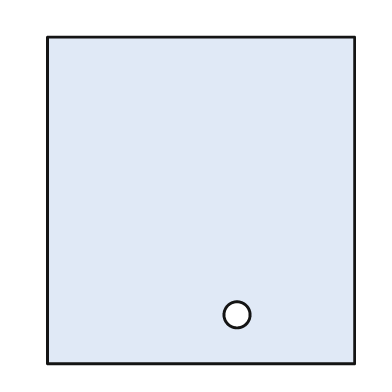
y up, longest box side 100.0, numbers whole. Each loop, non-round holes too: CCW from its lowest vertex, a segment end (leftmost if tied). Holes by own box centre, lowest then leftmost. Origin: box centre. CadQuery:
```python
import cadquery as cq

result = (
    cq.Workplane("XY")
    .moveTo(-47.0, -50.0)
    .lineTo(47.0, -50.0)
    .lineTo(47.0, 50.0)
    .lineTo(-47.0, 50.0)
    .close()
    .moveTo(11.0, -35.0)
    .circle(4.0)
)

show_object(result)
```